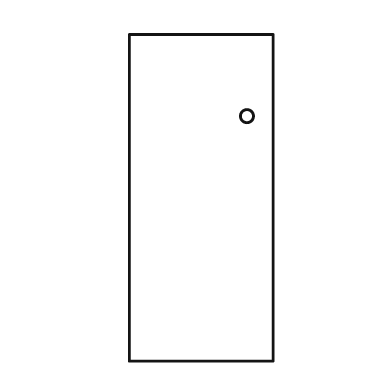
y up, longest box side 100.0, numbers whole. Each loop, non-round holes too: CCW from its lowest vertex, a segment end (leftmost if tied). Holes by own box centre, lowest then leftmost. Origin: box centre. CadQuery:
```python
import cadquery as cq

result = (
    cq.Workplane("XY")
    .moveTo(-22.0, -50.0)
    .lineTo(22.0, -50.0)
    .lineTo(22.0, 50.0)
    .lineTo(-22.0, 50.0)
    .close()
    .moveTo(14.0, 25.0)
    .circle(2.0)
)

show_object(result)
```